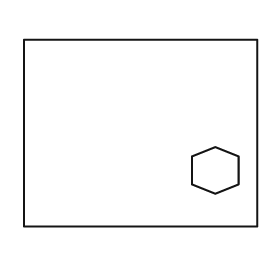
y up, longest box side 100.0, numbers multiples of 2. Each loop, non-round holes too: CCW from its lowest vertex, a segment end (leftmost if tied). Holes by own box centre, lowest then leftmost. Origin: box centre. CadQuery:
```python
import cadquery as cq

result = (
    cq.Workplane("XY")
    .moveTo(-50.0, -40.0)
    .lineTo(50.0, -40.0)
    .lineTo(50.0, 40.0)
    .lineTo(-50.0, 40.0)
    .close()
    .moveTo(32.0, -26.0)
    .lineTo(42.0, -22.0)
    .lineTo(42.0, -10.0)
    .lineTo(32.0, -6.0)
    .lineTo(22.0, -10.0)
    .lineTo(22.0, -22.0)
    .close()
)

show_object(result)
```